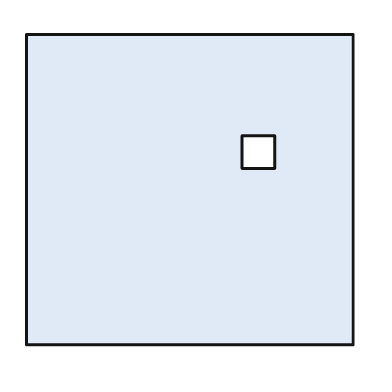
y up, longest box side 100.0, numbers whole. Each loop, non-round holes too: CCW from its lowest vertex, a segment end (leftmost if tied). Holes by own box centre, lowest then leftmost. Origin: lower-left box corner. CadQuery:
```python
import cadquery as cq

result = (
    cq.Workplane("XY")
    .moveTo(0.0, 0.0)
    .lineTo(100.0, 0.0)
    .lineTo(100.0, 95.0)
    .lineTo(0.0, 95.0)
    .close()
    .moveTo(66.0, 54.0)
    .lineTo(76.0, 54.0)
    .lineTo(76.0, 64.0)
    .lineTo(66.0, 64.0)
    .close()
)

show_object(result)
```